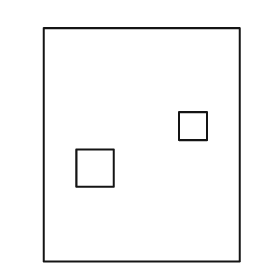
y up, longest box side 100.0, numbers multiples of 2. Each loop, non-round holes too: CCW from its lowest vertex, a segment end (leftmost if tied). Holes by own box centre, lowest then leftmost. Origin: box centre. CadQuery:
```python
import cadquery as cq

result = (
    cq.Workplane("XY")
    .moveTo(-42.0, -50.0)
    .lineTo(42.0, -50.0)
    .lineTo(42.0, 50.0)
    .lineTo(-42.0, 50.0)
    .close()
    .moveTo(-28.0, -18.0)
    .lineTo(-12.0, -18.0)
    .lineTo(-12.0, -2.0)
    .lineTo(-28.0, -2.0)
    .close()
    .moveTo(16.0, 2.0)
    .lineTo(28.0, 2.0)
    .lineTo(28.0, 14.0)
    .lineTo(16.0, 14.0)
    .close()
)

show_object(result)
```